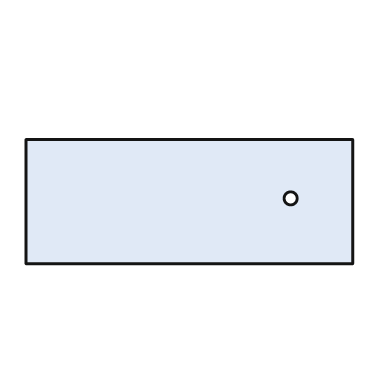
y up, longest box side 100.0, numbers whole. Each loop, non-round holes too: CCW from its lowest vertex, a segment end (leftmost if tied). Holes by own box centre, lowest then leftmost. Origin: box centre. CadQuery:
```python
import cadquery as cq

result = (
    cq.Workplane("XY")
    .moveTo(-50.0, -19.0)
    .lineTo(50.0, -19.0)
    .lineTo(50.0, 19.0)
    .lineTo(-50.0, 19.0)
    .close()
    .moveTo(31.0, 1.0)
    .circle(2.0)
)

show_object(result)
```